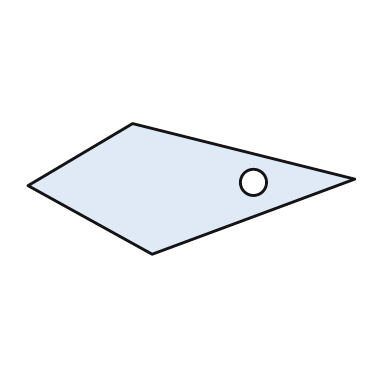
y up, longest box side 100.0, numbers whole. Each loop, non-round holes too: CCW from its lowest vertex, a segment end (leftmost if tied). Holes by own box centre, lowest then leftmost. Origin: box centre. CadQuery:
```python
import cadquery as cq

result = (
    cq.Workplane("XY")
    .moveTo(-12.0, -20.0)
    .lineTo(50.0, 3.0)
    .lineTo(-18.0, 20.0)
    .lineTo(-50.0, 1.0)
    .close()
    .moveTo(19.0, 2.0)
    .circle(4.0)
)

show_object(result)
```